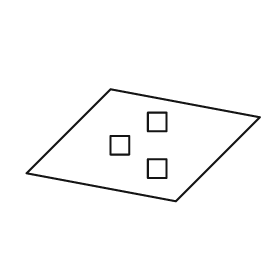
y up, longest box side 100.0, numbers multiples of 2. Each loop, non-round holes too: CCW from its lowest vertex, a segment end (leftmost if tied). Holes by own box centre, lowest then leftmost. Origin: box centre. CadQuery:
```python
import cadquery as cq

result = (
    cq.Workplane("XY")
    .moveTo(14.0, -24.0)
    .lineTo(50.0, 12.0)
    .lineTo(-14.0, 24.0)
    .lineTo(-50.0, -12.0)
    .close()
    .moveTo(2.0, -14.0)
    .lineTo(10.0, -14.0)
    .lineTo(10.0, -6.0)
    .lineTo(2.0, -6.0)
    .close()
    .moveTo(-14.0, -4.0)
    .lineTo(-6.0, -4.0)
    .lineTo(-6.0, 4.0)
    .lineTo(-14.0, 4.0)
    .close()
    .moveTo(2.0, 6.0)
    .lineTo(10.0, 6.0)
    .lineTo(10.0, 14.0)
    .lineTo(2.0, 14.0)
    .close()
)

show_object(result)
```